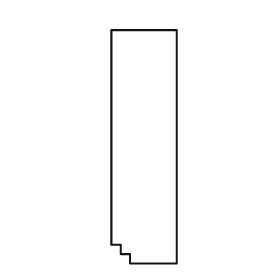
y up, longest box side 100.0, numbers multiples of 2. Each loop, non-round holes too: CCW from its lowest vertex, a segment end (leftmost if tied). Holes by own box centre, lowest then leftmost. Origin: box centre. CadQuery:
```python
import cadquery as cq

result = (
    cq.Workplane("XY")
    .moveTo(-6.0, -50.0)
    .lineTo(14.0, -50.0)
    .lineTo(14.0, 50.0)
    .lineTo(-14.0, 50.0)
    .lineTo(-14.0, -42.0)
    .lineTo(-10.0, -42.0)
    .lineTo(-10.0, -46.0)
    .lineTo(-6.0, -46.0)
    .close()
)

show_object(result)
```